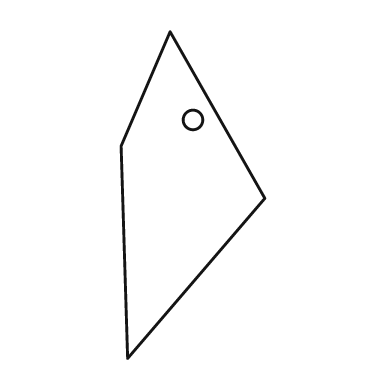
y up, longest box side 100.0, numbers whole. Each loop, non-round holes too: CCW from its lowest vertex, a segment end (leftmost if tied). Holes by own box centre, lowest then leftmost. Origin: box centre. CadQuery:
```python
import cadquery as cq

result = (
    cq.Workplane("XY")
    .moveTo(-20.0, -50.0)
    .lineTo(22.0, -1.0)
    .lineTo(-7.0, 50.0)
    .lineTo(-22.0, 15.0)
    .close()
    .moveTo(0.0, 23.0)
    .circle(3.0)
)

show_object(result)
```